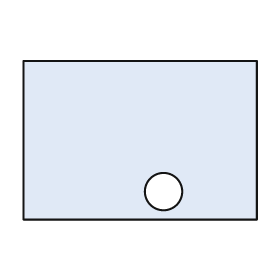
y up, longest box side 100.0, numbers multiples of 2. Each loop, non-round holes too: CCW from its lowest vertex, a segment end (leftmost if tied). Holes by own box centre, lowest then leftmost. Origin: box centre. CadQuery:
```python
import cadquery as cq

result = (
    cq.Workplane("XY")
    .moveTo(-50.0, -34.0)
    .lineTo(50.0, -34.0)
    .lineTo(50.0, 34.0)
    .lineTo(-50.0, 34.0)
    .close()
    .moveTo(10.0, -22.0)
    .circle(8.0)
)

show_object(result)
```